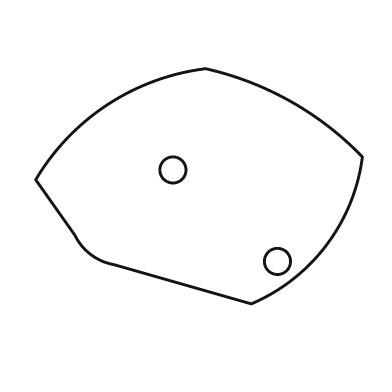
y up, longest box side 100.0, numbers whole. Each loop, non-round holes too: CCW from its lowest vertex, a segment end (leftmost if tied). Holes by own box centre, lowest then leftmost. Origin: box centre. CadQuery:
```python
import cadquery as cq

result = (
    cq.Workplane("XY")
    .moveTo(16.0, -36.0)
    .threePointArc((39.0, -18.0), (50.0, 9.0))
    .threePointArc((28.0, 26.0), (2.0, 36.0))
    .threePointArc((-28.0, 25.0), (-50.0, 2.0))
    .lineTo(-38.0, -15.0)
    .threePointArc((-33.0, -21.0), (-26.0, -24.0))
    .close()
    .moveTo(24.0, -23.0)
    .circle(4.0)
    .moveTo(-8.0, 5.0)
    .circle(4.0)
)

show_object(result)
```